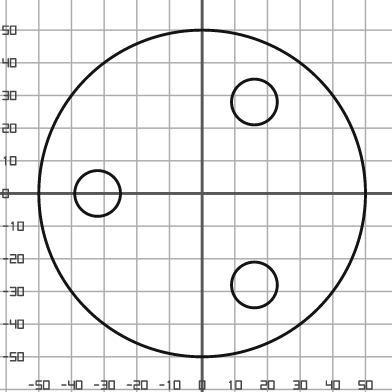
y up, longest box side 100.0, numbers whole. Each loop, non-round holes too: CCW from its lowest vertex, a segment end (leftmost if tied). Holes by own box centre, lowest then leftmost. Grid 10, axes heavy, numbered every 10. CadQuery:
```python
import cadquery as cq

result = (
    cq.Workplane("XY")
    .moveTo(0.0, 0.0)
    .circle(50.0)
    .moveTo(16.0, -28.0)
    .circle(7.0)
    .moveTo(-32.0, 0.0)
    .circle(7.0)
    .moveTo(16.0, 28.0)
    .circle(7.0)
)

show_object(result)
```